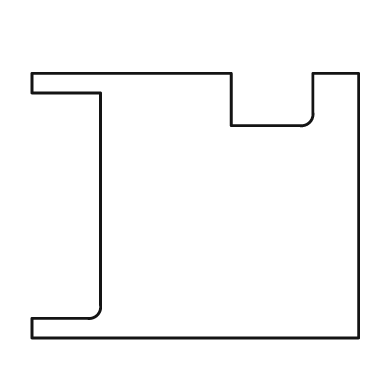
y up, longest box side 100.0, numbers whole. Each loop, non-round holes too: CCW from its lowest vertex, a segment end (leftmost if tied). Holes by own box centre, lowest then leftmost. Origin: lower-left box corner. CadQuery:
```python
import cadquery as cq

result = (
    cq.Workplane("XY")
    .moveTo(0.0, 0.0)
    .lineTo(100.0, 0.0)
    .lineTo(100.0, 81.0)
    .lineTo(86.0, 81.0)
    .lineTo(86.0, 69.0)
    .threePointArc((85.0, 66.0), (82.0, 65.0))
    .lineTo(61.0, 65.0)
    .lineTo(61.0, 81.0)
    .lineTo(0.0, 81.0)
    .lineTo(0.0, 75.0)
    .lineTo(21.0, 75.0)
    .lineTo(21.0, 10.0)
    .threePointArc((20.0, 7.0), (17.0, 6.0))
    .lineTo(0.0, 6.0)
    .close()
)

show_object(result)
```